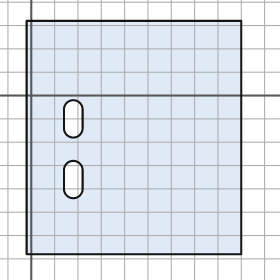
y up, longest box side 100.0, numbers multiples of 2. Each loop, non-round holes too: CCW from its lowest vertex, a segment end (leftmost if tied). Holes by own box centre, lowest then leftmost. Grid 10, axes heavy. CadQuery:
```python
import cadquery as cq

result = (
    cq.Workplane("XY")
    .moveTo(-2.0, -68.0)
    .lineTo(90.0, -68.0)
    .lineTo(90.0, 32.0)
    .lineTo(-2.0, 32.0)
    .close()
    .moveTo(14.0, -40.0)
    .threePointArc((18.0, -44.0), (22.0, -40.0))
    .lineTo(22.0, -32.0)
    .threePointArc((18.0, -28.0), (14.0, -32.0))
    .close()
    .moveTo(14.0, -14.0)
    .threePointArc((18.0, -18.0), (22.0, -14.0))
    .lineTo(22.0, -6.0)
    .threePointArc((18.0, -2.0), (14.0, -6.0))
    .close()
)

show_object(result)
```